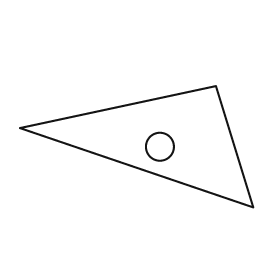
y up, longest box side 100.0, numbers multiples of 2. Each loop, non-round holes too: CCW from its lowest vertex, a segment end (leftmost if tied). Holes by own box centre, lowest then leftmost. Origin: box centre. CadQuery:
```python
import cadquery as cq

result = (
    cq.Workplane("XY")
    .moveTo(50.0, -26.0)
    .lineTo(34.0, 26.0)
    .lineTo(-50.0, 8.0)
    .close()
    .moveTo(10.0, 0.0)
    .circle(6.0)
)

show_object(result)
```